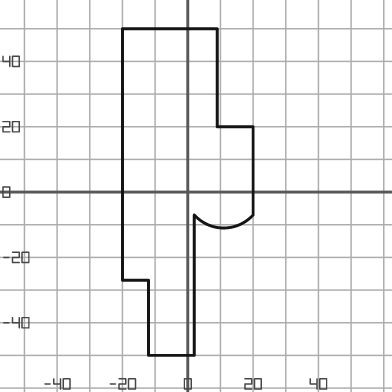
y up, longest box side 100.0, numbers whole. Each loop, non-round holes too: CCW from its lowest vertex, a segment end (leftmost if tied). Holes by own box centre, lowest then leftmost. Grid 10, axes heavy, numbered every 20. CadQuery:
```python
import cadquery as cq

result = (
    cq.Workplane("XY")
    .moveTo(-12.0, -50.0)
    .lineTo(2.0, -50.0)
    .lineTo(2.0, -7.0)
    .threePointArc((11.0, -11.0), (20.0, -7.0))
    .lineTo(20.0, 20.0)
    .lineTo(9.0, 20.0)
    .lineTo(9.0, 50.0)
    .lineTo(-20.0, 50.0)
    .lineTo(-20.0, -27.0)
    .lineTo(-12.0, -27.0)
    .close()
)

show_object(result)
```